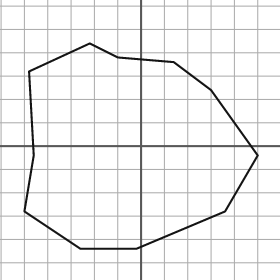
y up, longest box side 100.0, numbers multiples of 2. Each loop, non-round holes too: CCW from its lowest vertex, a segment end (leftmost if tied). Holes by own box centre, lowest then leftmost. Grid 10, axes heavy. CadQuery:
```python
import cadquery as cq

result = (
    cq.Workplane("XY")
    .moveTo(-26.0, -44.0)
    .lineTo(-2.0, -44.0)
    .lineTo(36.0, -28.0)
    .lineTo(50.0, -4.0)
    .lineTo(30.0, 24.0)
    .lineTo(14.0, 36.0)
    .lineTo(-10.0, 38.0)
    .lineTo(-22.0, 44.0)
    .lineTo(-48.0, 32.0)
    .lineTo(-46.0, -4.0)
    .lineTo(-50.0, -28.0)
    .close()
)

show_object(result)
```